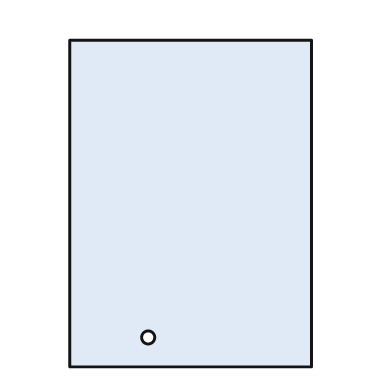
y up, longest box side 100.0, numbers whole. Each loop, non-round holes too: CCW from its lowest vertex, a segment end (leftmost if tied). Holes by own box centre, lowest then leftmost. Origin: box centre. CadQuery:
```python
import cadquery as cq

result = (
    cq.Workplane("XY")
    .moveTo(-37.0, -50.0)
    .lineTo(37.0, -50.0)
    .lineTo(37.0, 50.0)
    .lineTo(-37.0, 50.0)
    .close()
    .moveTo(-13.0, -41.0)
    .circle(2.0)
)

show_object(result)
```